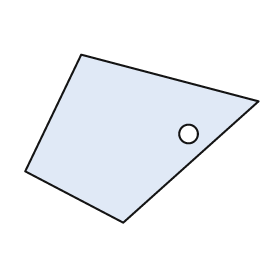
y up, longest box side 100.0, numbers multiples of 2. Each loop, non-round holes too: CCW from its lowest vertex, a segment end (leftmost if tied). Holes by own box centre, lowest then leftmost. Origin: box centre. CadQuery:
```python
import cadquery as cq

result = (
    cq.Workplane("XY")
    .moveTo(-8.0, -36.0)
    .lineTo(50.0, 16.0)
    .lineTo(-26.0, 36.0)
    .lineTo(-50.0, -14.0)
    .close()
    .moveTo(20.0, 2.0)
    .circle(4.0)
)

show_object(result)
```